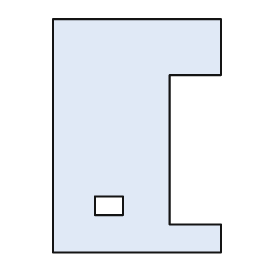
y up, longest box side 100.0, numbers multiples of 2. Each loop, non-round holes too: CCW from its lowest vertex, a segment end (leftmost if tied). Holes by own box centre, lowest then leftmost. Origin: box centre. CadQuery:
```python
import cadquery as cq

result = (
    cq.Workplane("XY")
    .moveTo(-36.0, -50.0)
    .lineTo(36.0, -50.0)
    .lineTo(36.0, -38.0)
    .lineTo(14.0, -38.0)
    .lineTo(14.0, 26.0)
    .lineTo(36.0, 26.0)
    .lineTo(36.0, 50.0)
    .lineTo(-36.0, 50.0)
    .close()
    .moveTo(-18.0, -34.0)
    .lineTo(-6.0, -34.0)
    .lineTo(-6.0, -26.0)
    .lineTo(-18.0, -26.0)
    .close()
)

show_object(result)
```